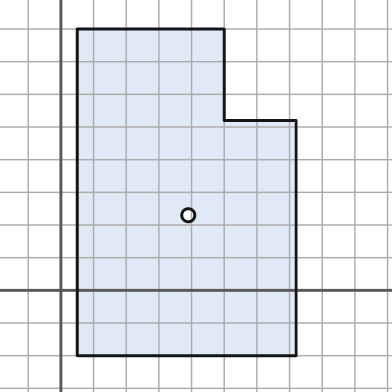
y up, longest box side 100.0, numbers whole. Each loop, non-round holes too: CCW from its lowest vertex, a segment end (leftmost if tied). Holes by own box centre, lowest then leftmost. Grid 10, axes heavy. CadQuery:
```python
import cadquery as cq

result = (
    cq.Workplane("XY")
    .moveTo(5.0, -20.0)
    .lineTo(72.0, -20.0)
    .lineTo(72.0, 52.0)
    .lineTo(50.0, 52.0)
    .lineTo(50.0, 80.0)
    .lineTo(5.0, 80.0)
    .close()
    .moveTo(39.0, 23.0)
    .circle(2.0)
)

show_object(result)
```